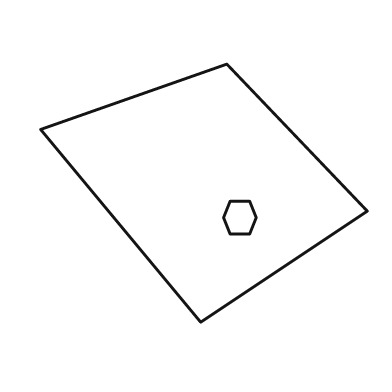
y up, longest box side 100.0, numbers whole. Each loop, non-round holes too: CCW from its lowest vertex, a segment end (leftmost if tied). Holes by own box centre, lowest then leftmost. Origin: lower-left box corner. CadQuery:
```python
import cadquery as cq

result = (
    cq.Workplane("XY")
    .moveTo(49.0, 0.0)
    .lineTo(100.0, 34.0)
    .lineTo(57.0, 79.0)
    .lineTo(0.0, 59.0)
    .close()
    .moveTo(58.0, 27.0)
    .lineTo(64.0, 27.0)
    .lineTo(66.0, 32.0)
    .lineTo(64.0, 37.0)
    .lineTo(58.0, 37.0)
    .lineTo(56.0, 32.0)
    .close()
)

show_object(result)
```